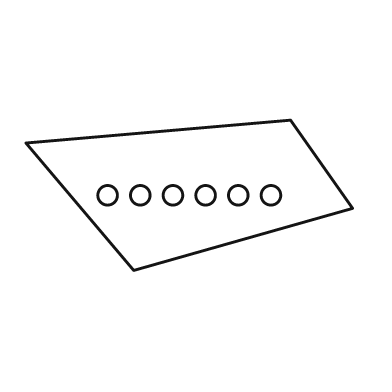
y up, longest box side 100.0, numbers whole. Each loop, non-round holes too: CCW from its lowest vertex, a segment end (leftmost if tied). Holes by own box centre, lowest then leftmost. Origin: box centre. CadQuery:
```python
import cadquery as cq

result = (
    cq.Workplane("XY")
    .moveTo(-17.0, -23.0)
    .lineTo(50.0, -4.0)
    .lineTo(31.0, 23.0)
    .lineTo(-50.0, 16.0)
    .close()
    .moveTo(-25.0, 0.0)
    .circle(3.0)
    .moveTo(-15.0, 0.0)
    .circle(3.0)
    .moveTo(-5.0, 0.0)
    .circle(3.0)
    .moveTo(5.0, 0.0)
    .circle(3.0)
    .moveTo(15.0, 0.0)
    .circle(3.0)
    .moveTo(25.0, 0.0)
    .circle(3.0)
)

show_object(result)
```